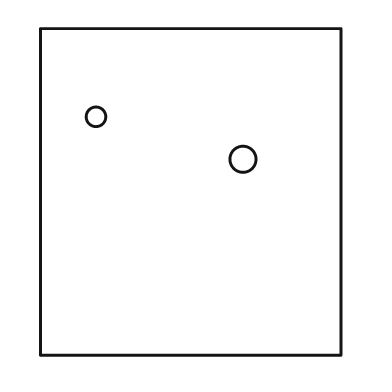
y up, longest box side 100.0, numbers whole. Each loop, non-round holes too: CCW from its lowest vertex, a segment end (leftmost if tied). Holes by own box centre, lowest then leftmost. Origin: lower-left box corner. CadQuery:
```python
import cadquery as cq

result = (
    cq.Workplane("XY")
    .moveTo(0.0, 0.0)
    .lineTo(92.0, 0.0)
    .lineTo(92.0, 100.0)
    .lineTo(0.0, 100.0)
    .close()
    .moveTo(62.0, 60.0)
    .circle(4.0)
    .moveTo(17.0, 73.0)
    .circle(3.0)
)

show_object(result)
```